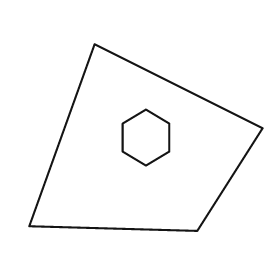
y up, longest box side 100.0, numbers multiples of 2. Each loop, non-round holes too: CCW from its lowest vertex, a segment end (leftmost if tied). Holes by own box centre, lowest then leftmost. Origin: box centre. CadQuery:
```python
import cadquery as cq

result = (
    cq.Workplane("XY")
    .moveTo(22.0, -40.0)
    .lineTo(50.0, 4.0)
    .lineTo(-22.0, 40.0)
    .lineTo(-50.0, -38.0)
    .close()
    .moveTo(0.0, -12.0)
    .lineTo(10.0, -6.0)
    .lineTo(10.0, 6.0)
    .lineTo(0.0, 12.0)
    .lineTo(-10.0, 6.0)
    .lineTo(-10.0, -6.0)
    .close()
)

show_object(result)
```